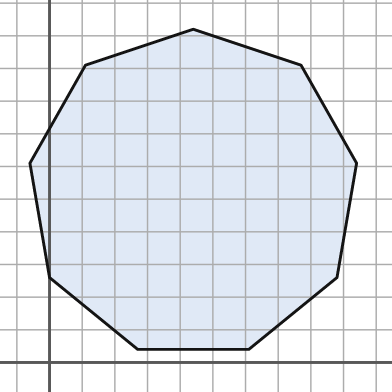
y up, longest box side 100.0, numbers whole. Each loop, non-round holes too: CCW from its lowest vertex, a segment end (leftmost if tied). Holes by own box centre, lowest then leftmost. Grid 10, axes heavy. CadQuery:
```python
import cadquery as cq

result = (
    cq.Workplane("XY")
    .moveTo(27.0, 4.0)
    .lineTo(61.0, 4.0)
    .lineTo(88.0, 26.0)
    .lineTo(94.0, 61.0)
    .lineTo(77.0, 91.0)
    .lineTo(44.0, 102.0)
    .lineTo(11.0, 91.0)
    .lineTo(-6.0, 61.0)
    .lineTo(0.0, 26.0)
    .close()
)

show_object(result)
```